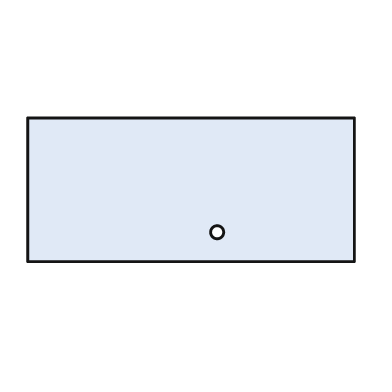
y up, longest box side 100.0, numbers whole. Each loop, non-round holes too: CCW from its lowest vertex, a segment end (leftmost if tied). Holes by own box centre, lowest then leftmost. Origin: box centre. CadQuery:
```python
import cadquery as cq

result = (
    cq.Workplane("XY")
    .moveTo(-50.0, -22.0)
    .lineTo(50.0, -22.0)
    .lineTo(50.0, 22.0)
    .lineTo(-50.0, 22.0)
    .close()
    .moveTo(8.0, -13.0)
    .circle(2.0)
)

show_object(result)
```